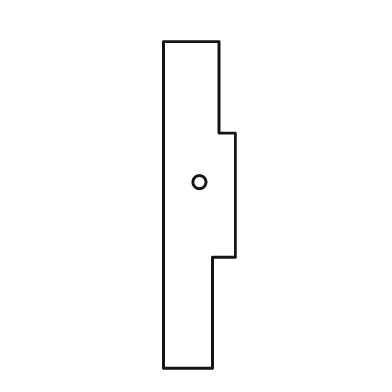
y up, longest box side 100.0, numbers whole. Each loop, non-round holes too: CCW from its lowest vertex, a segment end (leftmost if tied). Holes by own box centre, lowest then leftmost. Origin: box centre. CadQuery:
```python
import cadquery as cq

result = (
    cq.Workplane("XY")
    .moveTo(-11.0, -50.0)
    .lineTo(4.0, -50.0)
    .lineTo(4.0, -16.0)
    .lineTo(11.0, -16.0)
    .lineTo(11.0, 22.0)
    .lineTo(6.0, 22.0)
    .lineTo(6.0, 50.0)
    .lineTo(-11.0, 50.0)
    .close()
    .moveTo(0.0, 7.0)
    .circle(2.0)
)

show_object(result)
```